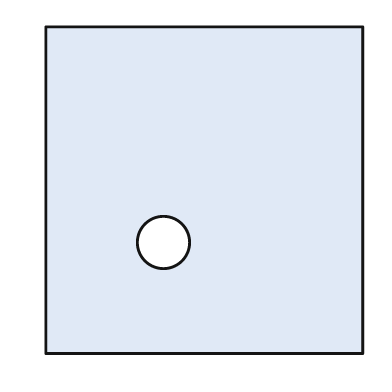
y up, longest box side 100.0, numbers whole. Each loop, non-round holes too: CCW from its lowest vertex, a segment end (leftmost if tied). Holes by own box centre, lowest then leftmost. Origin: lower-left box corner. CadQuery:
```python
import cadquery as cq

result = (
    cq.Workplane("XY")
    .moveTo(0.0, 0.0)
    .lineTo(97.0, 0.0)
    .lineTo(97.0, 100.0)
    .lineTo(0.0, 100.0)
    .close()
    .moveTo(36.0, 34.0)
    .circle(8.0)
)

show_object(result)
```